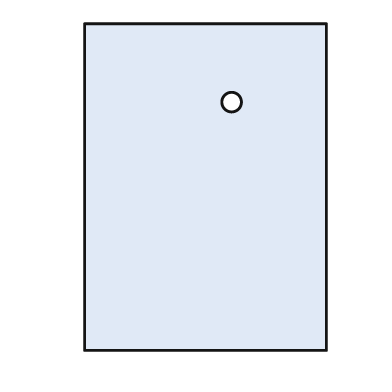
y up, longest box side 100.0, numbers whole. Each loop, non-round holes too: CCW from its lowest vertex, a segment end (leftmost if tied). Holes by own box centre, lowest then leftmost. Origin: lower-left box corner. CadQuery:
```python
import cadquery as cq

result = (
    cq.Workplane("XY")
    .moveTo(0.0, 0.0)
    .lineTo(74.0, 0.0)
    .lineTo(74.0, 100.0)
    .lineTo(0.0, 100.0)
    .close()
    .moveTo(45.0, 76.0)
    .circle(3.0)
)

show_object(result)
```